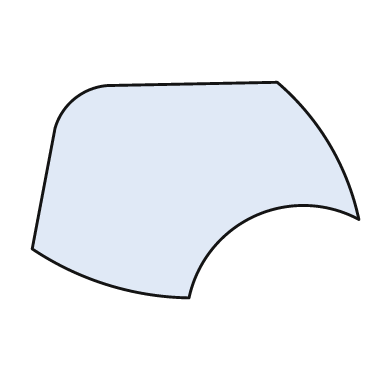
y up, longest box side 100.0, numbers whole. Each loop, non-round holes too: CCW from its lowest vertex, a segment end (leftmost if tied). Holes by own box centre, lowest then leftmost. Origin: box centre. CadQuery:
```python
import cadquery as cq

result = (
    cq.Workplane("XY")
    .moveTo(-2.0, -33.0)
    .threePointArc((18.0, -8.0), (50.0, -9.0))
    .threePointArc((41.0, 14.0), (25.0, 33.0))
    .lineTo(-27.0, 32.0)
    .threePointArc((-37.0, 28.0), (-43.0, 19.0))
    .lineTo(-50.0, -18.0)
    .threePointArc((-27.0, -29.0), (-2.0, -33.0))
    .close()
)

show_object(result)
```